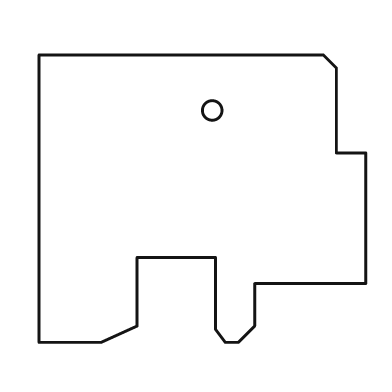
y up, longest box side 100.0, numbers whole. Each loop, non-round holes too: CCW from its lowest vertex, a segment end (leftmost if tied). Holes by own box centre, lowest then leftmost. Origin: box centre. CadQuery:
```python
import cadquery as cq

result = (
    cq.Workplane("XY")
    .moveTo(-50.0, -44.0)
    .lineTo(-31.0, -44.0)
    .lineTo(-20.0, -39.0)
    .lineTo(-20.0, -18.0)
    .lineTo(4.0, -18.0)
    .lineTo(4.0, -40.0)
    .lineTo(7.0, -44.0)
    .lineTo(11.0, -44.0)
    .lineTo(16.0, -39.0)
    .lineTo(16.0, -26.0)
    .lineTo(50.0, -26.0)
    .lineTo(50.0, 14.0)
    .lineTo(41.0, 14.0)
    .lineTo(41.0, 40.0)
    .lineTo(37.0, 44.0)
    .lineTo(-50.0, 44.0)
    .close()
    .moveTo(3.0, 27.0)
    .circle(3.0)
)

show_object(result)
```